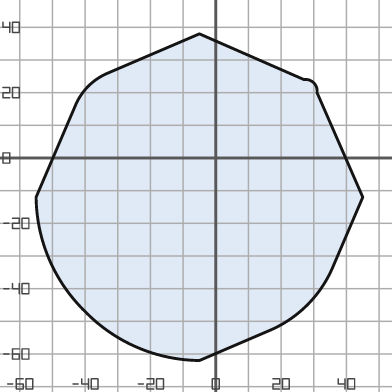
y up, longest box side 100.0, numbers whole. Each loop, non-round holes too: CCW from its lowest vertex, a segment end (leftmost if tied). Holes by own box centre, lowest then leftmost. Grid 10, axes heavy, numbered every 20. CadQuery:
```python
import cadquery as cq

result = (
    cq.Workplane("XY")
    .moveTo(-5.0, -62.0)
    .lineTo(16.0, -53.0)
    .threePointArc((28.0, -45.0), (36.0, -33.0))
    .lineTo(45.0, -12.0)
    .lineTo(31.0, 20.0)
    .threePointArc((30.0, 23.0), (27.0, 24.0))
    .lineTo(-5.0, 38.0)
    .lineTo(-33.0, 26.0)
    .threePointArc((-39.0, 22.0), (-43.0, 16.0))
    .lineTo(-55.0, -12.0)
    .threePointArc((-51.0, -31.0), (-40.0, -47.0))
    .threePointArc((-24.0, -58.0), (-5.0, -62.0))
    .close()
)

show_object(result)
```